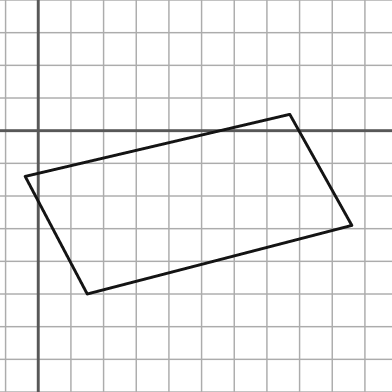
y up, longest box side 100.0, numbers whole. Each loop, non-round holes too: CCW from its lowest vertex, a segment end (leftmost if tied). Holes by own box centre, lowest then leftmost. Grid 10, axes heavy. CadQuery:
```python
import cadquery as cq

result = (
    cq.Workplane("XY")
    .moveTo(15.0, -50.0)
    .lineTo(96.0, -29.0)
    .lineTo(77.0, 5.0)
    .lineTo(-4.0, -14.0)
    .close()
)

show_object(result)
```